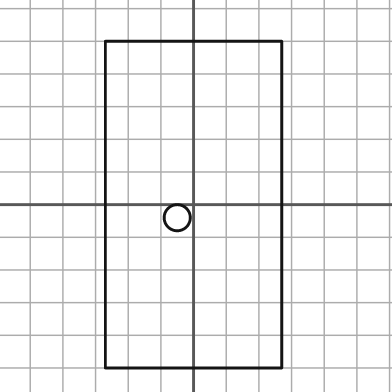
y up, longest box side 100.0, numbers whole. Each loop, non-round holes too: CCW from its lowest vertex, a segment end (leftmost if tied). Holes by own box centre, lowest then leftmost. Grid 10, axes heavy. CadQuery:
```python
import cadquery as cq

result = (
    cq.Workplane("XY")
    .moveTo(-27.0, -50.0)
    .lineTo(27.0, -50.0)
    .lineTo(27.0, 50.0)
    .lineTo(-27.0, 50.0)
    .close()
    .moveTo(-5.0, -4.0)
    .circle(4.0)
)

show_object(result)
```